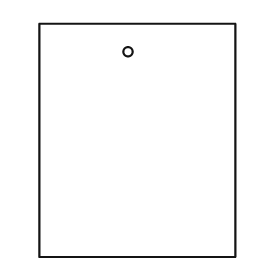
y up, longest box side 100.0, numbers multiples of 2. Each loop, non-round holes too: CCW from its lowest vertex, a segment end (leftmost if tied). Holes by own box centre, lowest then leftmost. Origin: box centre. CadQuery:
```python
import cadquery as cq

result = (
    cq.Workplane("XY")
    .moveTo(-42.0, -50.0)
    .lineTo(42.0, -50.0)
    .lineTo(42.0, 50.0)
    .lineTo(-42.0, 50.0)
    .close()
    .moveTo(-4.0, 38.0)
    .circle(2.0)
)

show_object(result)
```